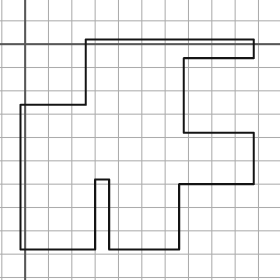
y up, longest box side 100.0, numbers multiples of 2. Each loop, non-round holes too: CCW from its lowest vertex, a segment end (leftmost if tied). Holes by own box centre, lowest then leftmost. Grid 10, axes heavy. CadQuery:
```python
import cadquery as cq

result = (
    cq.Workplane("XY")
    .moveTo(-2.0, -88.0)
    .lineTo(30.0, -88.0)
    .lineTo(30.0, -58.0)
    .lineTo(36.0, -58.0)
    .lineTo(36.0, -88.0)
    .lineTo(66.0, -88.0)
    .lineTo(66.0, -60.0)
    .lineTo(98.0, -60.0)
    .lineTo(98.0, -38.0)
    .lineTo(68.0, -38.0)
    .lineTo(68.0, -6.0)
    .lineTo(98.0, -6.0)
    .lineTo(98.0, 2.0)
    .lineTo(26.0, 2.0)
    .lineTo(26.0, -26.0)
    .lineTo(-2.0, -26.0)
    .close()
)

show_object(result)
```